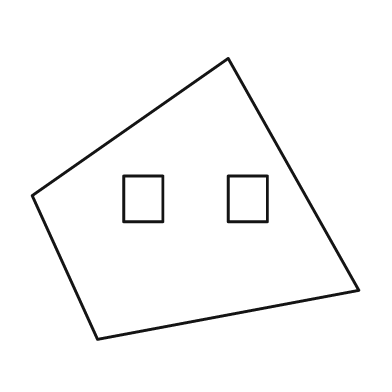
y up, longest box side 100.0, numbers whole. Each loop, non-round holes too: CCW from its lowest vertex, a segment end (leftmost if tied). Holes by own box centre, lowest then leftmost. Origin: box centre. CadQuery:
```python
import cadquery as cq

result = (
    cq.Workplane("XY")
    .moveTo(-30.0, -43.0)
    .lineTo(50.0, -28.0)
    .lineTo(10.0, 43.0)
    .lineTo(-50.0, 1.0)
    .close()
    .moveTo(-22.0, -7.0)
    .lineTo(-10.0, -7.0)
    .lineTo(-10.0, 7.0)
    .lineTo(-22.0, 7.0)
    .close()
    .moveTo(10.0, -7.0)
    .lineTo(22.0, -7.0)
    .lineTo(22.0, 7.0)
    .lineTo(10.0, 7.0)
    .close()
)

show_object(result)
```